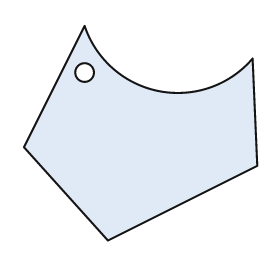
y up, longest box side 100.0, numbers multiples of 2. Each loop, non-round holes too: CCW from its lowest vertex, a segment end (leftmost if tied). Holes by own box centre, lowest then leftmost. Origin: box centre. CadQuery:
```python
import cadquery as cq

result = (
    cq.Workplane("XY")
    .moveTo(-14.0, -46.0)
    .lineTo(50.0, -14.0)
    .lineTo(48.0, 32.0)
    .threePointArc((8.0, 18.0), (-24.0, 46.0))
    .lineTo(-50.0, -6.0)
    .close()
    .moveTo(-24.0, 26.0)
    .circle(4.0)
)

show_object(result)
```